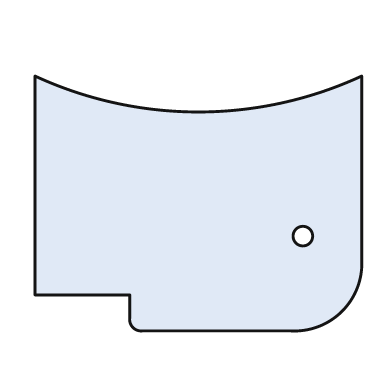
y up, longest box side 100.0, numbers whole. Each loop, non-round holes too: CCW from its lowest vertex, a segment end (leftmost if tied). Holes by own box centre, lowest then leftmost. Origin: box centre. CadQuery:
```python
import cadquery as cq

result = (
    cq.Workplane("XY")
    .moveTo(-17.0, -39.0)
    .lineTo(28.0, -39.0)
    .threePointArc((44.0, -33.0), (50.0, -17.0))
    .lineTo(50.0, 39.0)
    .threePointArc((0.0, 28.0), (-50.0, 39.0))
    .lineTo(-50.0, -28.0)
    .lineTo(-21.0, -28.0)
    .lineTo(-21.0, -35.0)
    .threePointArc((-20.0, -38.0), (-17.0, -39.0))
    .close()
    .moveTo(32.0, -10.0)
    .circle(3.0)
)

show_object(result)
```